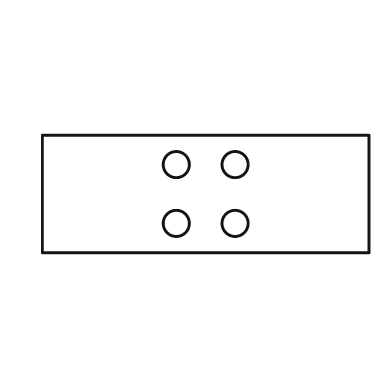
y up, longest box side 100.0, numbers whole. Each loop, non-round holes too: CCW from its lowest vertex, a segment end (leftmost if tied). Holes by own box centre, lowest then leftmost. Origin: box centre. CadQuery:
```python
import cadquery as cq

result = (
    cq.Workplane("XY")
    .moveTo(-50.0, -18.0)
    .lineTo(50.0, -18.0)
    .lineTo(50.0, 18.0)
    .lineTo(-50.0, 18.0)
    .close()
    .moveTo(-9.0, -9.0)
    .circle(4.0)
    .moveTo(9.0, -9.0)
    .circle(4.0)
    .moveTo(-9.0, 9.0)
    .circle(4.0)
    .moveTo(9.0, 9.0)
    .circle(4.0)
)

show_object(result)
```